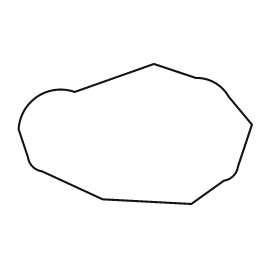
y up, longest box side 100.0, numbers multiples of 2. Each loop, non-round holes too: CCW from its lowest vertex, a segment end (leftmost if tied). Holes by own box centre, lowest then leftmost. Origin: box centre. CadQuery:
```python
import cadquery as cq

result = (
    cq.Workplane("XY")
    .moveTo(24.0, -30.0)
    .lineTo(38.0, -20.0)
    .threePointArc((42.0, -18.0), (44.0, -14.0))
    .lineTo(50.0, 4.0)
    .lineTo(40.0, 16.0)
    .threePointArc((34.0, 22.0), (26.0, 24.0))
    .lineTo(8.0, 30.0)
    .lineTo(-26.0, 18.0)
    .threePointArc((-42.0, 16.0), (-50.0, 2.0))
    .lineTo(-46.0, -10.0)
    .threePointArc((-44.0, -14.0), (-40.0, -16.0))
    .lineTo(-14.0, -28.0)
    .close()
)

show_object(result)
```